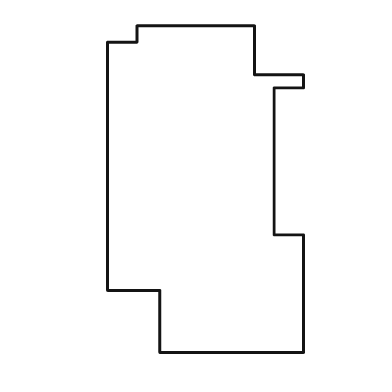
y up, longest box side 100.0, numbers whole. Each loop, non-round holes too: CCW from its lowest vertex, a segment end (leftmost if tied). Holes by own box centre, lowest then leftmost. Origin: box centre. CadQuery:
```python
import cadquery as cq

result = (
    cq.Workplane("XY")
    .moveTo(-14.0, -50.0)
    .lineTo(30.0, -50.0)
    .lineTo(30.0, -14.0)
    .lineTo(21.0, -14.0)
    .lineTo(21.0, 31.0)
    .lineTo(30.0, 31.0)
    .lineTo(30.0, 35.0)
    .lineTo(15.0, 35.0)
    .lineTo(15.0, 50.0)
    .lineTo(-21.0, 50.0)
    .lineTo(-21.0, 45.0)
    .lineTo(-30.0, 45.0)
    .lineTo(-30.0, -31.0)
    .lineTo(-14.0, -31.0)
    .close()
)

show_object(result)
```